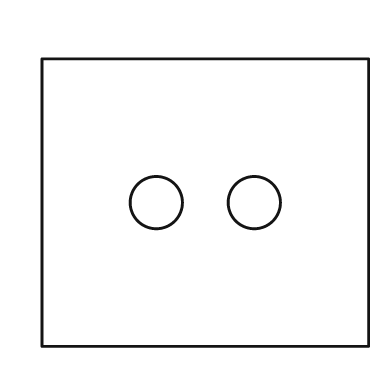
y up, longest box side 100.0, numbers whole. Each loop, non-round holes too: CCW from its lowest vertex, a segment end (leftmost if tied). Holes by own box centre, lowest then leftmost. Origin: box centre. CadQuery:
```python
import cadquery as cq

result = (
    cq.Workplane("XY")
    .moveTo(-50.0, -44.0)
    .lineTo(50.0, -44.0)
    .lineTo(50.0, 44.0)
    .lineTo(-50.0, 44.0)
    .close()
    .moveTo(-15.0, 0.0)
    .circle(8.0)
    .moveTo(15.0, 0.0)
    .circle(8.0)
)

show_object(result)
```